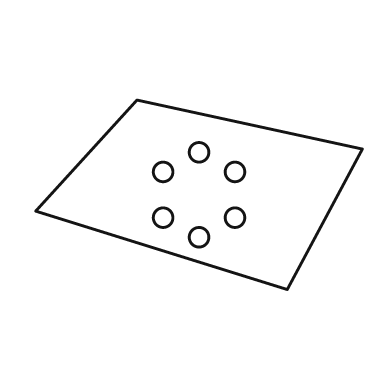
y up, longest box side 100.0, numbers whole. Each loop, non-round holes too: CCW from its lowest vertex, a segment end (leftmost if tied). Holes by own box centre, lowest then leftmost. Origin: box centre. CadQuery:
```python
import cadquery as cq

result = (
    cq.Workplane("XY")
    .moveTo(27.0, -29.0)
    .lineTo(50.0, 14.0)
    .lineTo(-19.0, 29.0)
    .lineTo(-50.0, -5.0)
    .close()
    .moveTo(0.0, -13.0)
    .circle(3.0)
    .moveTo(-11.0, -7.0)
    .circle(3.0)
    .moveTo(11.0, -7.0)
    .circle(3.0)
    .moveTo(-11.0, 7.0)
    .circle(3.0)
    .moveTo(11.0, 7.0)
    .circle(3.0)
    .moveTo(0.0, 13.0)
    .circle(3.0)
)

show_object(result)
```